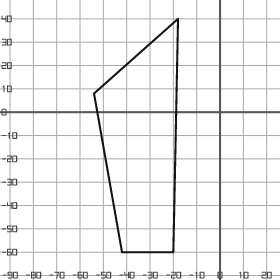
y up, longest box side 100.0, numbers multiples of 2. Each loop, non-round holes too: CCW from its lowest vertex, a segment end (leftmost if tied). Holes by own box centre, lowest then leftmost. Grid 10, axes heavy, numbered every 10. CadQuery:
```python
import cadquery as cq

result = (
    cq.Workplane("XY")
    .moveTo(-42.0, -60.0)
    .lineTo(-20.0, -60.0)
    .lineTo(-18.0, 40.0)
    .lineTo(-54.0, 8.0)
    .close()
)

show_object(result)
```